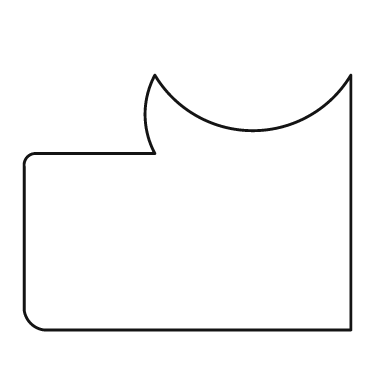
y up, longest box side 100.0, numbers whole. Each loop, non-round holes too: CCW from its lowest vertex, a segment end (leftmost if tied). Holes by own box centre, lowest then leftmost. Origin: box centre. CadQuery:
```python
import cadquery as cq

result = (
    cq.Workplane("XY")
    .moveTo(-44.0, -39.0)
    .lineTo(50.0, -39.0)
    .lineTo(50.0, 39.0)
    .threePointArc((20.0, 22.0), (-10.0, 39.0))
    .threePointArc((-13.0, 27.0), (-10.0, 15.0))
    .lineTo(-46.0, 15.0)
    .threePointArc((-49.0, 14.0), (-50.0, 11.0))
    .lineTo(-50.0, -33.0)
    .threePointArc((-48.0, -37.0), (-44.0, -39.0))
    .close()
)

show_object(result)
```